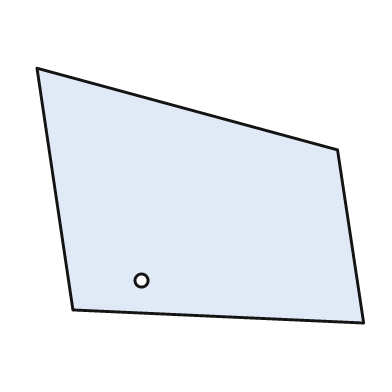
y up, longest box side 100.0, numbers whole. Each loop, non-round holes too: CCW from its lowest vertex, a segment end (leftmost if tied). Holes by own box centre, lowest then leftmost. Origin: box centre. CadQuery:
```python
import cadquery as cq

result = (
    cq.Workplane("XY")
    .moveTo(50.0, -39.0)
    .lineTo(42.0, 14.0)
    .lineTo(-50.0, 39.0)
    .lineTo(-39.0, -35.0)
    .close()
    .moveTo(-18.0, -26.0)
    .circle(2.0)
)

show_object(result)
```